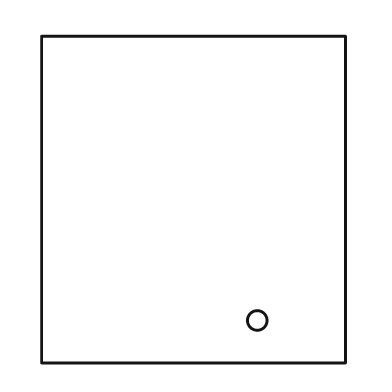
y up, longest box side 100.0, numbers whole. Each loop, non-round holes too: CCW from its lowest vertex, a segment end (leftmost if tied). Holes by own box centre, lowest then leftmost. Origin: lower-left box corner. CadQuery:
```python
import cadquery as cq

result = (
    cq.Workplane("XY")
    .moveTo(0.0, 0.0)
    .lineTo(93.0, 0.0)
    .lineTo(93.0, 100.0)
    .lineTo(0.0, 100.0)
    .close()
    .moveTo(66.0, 13.0)
    .circle(3.0)
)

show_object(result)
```